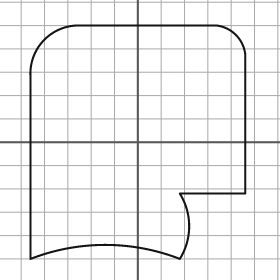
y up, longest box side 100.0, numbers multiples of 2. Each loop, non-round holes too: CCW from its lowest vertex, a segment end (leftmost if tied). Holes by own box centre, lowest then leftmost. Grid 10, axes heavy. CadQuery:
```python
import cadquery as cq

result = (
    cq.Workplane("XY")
    .moveTo(-46.0, -50.0)
    .threePointArc((-14.0, -44.0), (18.0, -50.0))
    .threePointArc((22.0, -36.0), (18.0, -22.0))
    .lineTo(46.0, -22.0)
    .lineTo(46.0, 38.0)
    .threePointArc((42.0, 46.0), (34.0, 50.0))
    .lineTo(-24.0, 50.0)
    .threePointArc((-40.0, 44.0), (-46.0, 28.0))
    .close()
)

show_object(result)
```